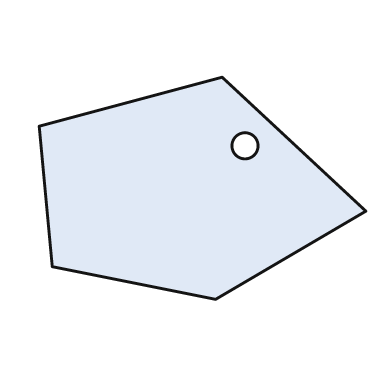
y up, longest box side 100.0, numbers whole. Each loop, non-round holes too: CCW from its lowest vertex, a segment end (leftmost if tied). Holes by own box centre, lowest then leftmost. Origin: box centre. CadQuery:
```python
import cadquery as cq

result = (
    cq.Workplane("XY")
    .moveTo(4.0, -34.0)
    .lineTo(50.0, -7.0)
    .lineTo(6.0, 34.0)
    .lineTo(-50.0, 19.0)
    .lineTo(-46.0, -24.0)
    .close()
    .moveTo(13.0, 13.0)
    .circle(4.0)
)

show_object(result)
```